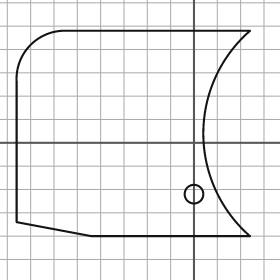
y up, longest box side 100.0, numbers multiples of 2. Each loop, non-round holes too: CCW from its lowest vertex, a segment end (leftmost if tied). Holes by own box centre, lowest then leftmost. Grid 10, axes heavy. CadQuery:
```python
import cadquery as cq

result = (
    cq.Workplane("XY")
    .moveTo(-44.0, -40.0)
    .lineTo(24.0, -40.0)
    .threePointArc((4.0, 4.0), (24.0, 48.0))
    .lineTo(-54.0, 48.0)
    .threePointArc((-70.0, 42.0), (-76.0, 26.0))
    .lineTo(-76.0, -34.0)
    .close()
    .moveTo(0.0, -22.0)
    .circle(4.0)
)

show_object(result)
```